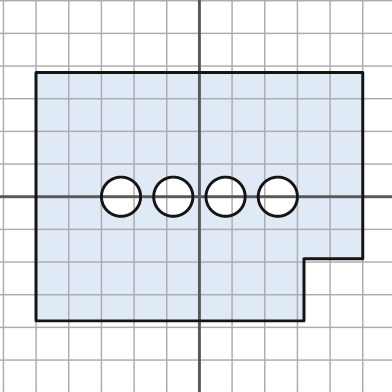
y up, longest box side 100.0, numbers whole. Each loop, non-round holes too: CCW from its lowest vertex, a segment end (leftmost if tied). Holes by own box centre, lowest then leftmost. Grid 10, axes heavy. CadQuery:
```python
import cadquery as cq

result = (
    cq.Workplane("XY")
    .moveTo(-50.0, -38.0)
    .lineTo(32.0, -38.0)
    .lineTo(32.0, -19.0)
    .lineTo(50.0, -19.0)
    .lineTo(50.0, 38.0)
    .lineTo(-50.0, 38.0)
    .close()
    .moveTo(-24.0, 0.0)
    .circle(6.0)
    .moveTo(-8.0, 0.0)
    .circle(6.0)
    .moveTo(8.0, 0.0)
    .circle(6.0)
    .moveTo(24.0, 0.0)
    .circle(6.0)
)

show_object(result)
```